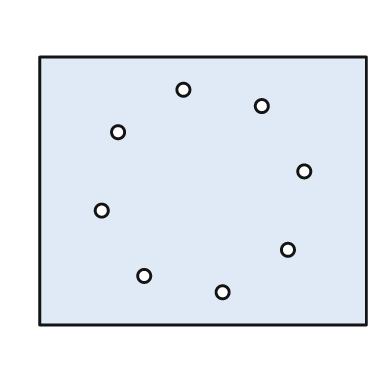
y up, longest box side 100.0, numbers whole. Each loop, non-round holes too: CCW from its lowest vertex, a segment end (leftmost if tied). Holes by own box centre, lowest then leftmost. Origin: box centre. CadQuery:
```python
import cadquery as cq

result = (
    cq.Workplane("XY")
    .moveTo(-50.0, -41.0)
    .lineTo(50.0, -41.0)
    .lineTo(50.0, 41.0)
    .lineTo(-50.0, 41.0)
    .close()
    .moveTo(6.0, -31.0)
    .circle(2.0)
    .moveTo(-18.0, -26.0)
    .circle(2.0)
    .moveTo(26.0, -18.0)
    .circle(2.0)
    .moveTo(-31.0, -6.0)
    .circle(2.0)
    .moveTo(31.0, 6.0)
    .circle(2.0)
    .moveTo(-26.0, 18.0)
    .circle(2.0)
    .moveTo(18.0, 26.0)
    .circle(2.0)
    .moveTo(-6.0, 31.0)
    .circle(2.0)
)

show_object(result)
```